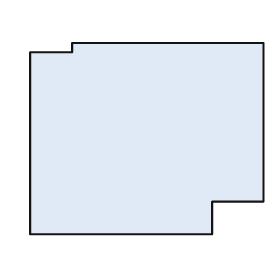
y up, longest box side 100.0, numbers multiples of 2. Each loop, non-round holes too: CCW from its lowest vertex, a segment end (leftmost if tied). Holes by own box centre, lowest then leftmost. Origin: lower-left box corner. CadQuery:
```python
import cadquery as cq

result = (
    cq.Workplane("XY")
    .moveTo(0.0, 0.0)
    .lineTo(78.0, 0.0)
    .lineTo(78.0, 14.0)
    .lineTo(100.0, 14.0)
    .lineTo(100.0, 82.0)
    .lineTo(18.0, 82.0)
    .lineTo(18.0, 78.0)
    .lineTo(0.0, 78.0)
    .close()
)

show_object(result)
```